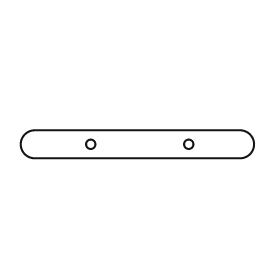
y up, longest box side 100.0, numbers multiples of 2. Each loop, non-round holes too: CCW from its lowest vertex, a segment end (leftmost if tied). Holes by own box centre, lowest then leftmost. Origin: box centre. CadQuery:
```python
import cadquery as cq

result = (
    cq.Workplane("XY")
    .moveTo(-44.0, -6.0)
    .lineTo(44.0, -6.0)
    .threePointArc((50.0, 0.0), (44.0, 6.0))
    .lineTo(-44.0, 6.0)
    .threePointArc((-50.0, 0.0), (-44.0, -6.0))
    .close()
    .moveTo(-20.0, 0.0)
    .circle(2.0)
    .moveTo(22.0, 0.0)
    .circle(2.0)
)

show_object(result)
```